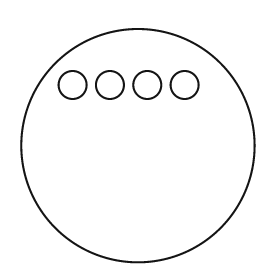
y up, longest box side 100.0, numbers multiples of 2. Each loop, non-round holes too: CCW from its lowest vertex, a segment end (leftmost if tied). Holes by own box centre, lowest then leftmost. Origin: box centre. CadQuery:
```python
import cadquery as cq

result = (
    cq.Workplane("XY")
    .moveTo(0.0, 0.0)
    .circle(50.0)
    .moveTo(-28.0, 26.0)
    .circle(6.0)
    .moveTo(-12.0, 26.0)
    .circle(6.0)
    .moveTo(4.0, 26.0)
    .circle(6.0)
    .moveTo(20.0, 26.0)
    .circle(6.0)
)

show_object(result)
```